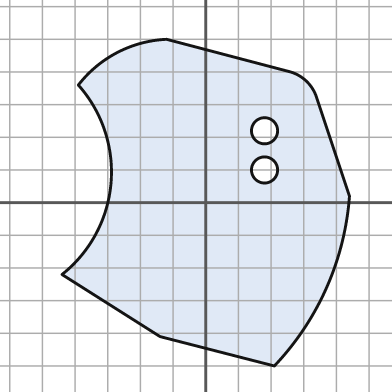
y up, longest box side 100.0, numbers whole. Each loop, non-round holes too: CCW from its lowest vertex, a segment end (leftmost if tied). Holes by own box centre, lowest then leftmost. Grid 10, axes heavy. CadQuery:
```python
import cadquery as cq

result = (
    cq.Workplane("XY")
    .moveTo(21.0, -50.0)
    .threePointArc((37.0, -26.0), (44.0, 2.0))
    .lineTo(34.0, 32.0)
    .threePointArc((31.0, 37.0), (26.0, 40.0))
    .lineTo(-12.0, 50.0)
    .threePointArc((-27.0, 46.0), (-39.0, 36.0))
    .threePointArc((-29.0, 6.0), (-44.0, -22.0))
    .lineTo(-14.0, -41.0)
    .close()
    .moveTo(18.0, 10.0)
    .circle(4.0)
    .moveTo(18.0, 22.0)
    .circle(4.0)
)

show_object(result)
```